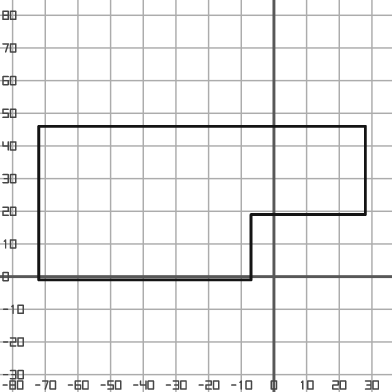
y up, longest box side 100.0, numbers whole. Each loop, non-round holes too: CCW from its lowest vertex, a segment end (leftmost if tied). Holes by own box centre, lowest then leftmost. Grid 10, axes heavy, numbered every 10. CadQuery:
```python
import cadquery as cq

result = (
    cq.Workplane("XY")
    .moveTo(-72.0, -1.0)
    .lineTo(-7.0, -1.0)
    .lineTo(-7.0, 19.0)
    .lineTo(28.0, 19.0)
    .lineTo(28.0, 46.0)
    .lineTo(-72.0, 46.0)
    .close()
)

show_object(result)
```